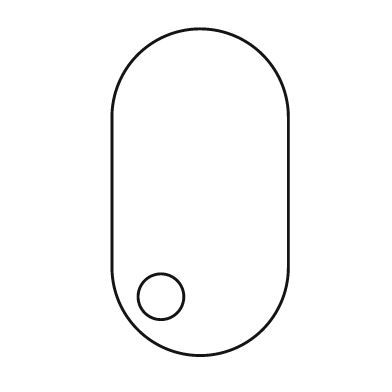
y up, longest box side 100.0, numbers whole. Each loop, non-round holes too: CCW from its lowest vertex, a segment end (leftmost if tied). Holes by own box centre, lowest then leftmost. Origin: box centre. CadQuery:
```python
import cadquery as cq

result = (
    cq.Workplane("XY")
    .moveTo(-27.0, -23.0)
    .threePointArc((0.0, -50.0), (27.0, -23.0))
    .lineTo(27.0, 23.0)
    .threePointArc((0.0, 50.0), (-27.0, 23.0))
    .close()
    .moveTo(-12.0, -32.0)
    .circle(7.0)
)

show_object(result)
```